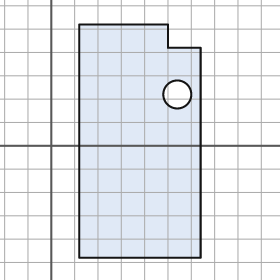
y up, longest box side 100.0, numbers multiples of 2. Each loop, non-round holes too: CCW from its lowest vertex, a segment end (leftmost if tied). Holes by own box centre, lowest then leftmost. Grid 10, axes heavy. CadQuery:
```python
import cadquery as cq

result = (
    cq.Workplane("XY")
    .moveTo(12.0, -48.0)
    .lineTo(64.0, -48.0)
    .lineTo(64.0, 42.0)
    .lineTo(50.0, 42.0)
    .lineTo(50.0, 52.0)
    .lineTo(12.0, 52.0)
    .close()
    .moveTo(54.0, 22.0)
    .circle(6.0)
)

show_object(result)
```